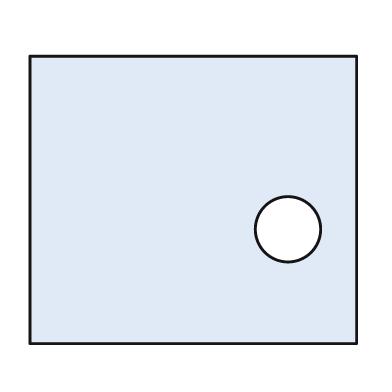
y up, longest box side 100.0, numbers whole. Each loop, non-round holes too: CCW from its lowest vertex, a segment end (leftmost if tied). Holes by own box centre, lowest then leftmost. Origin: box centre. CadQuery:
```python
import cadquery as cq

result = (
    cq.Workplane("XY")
    .moveTo(-50.0, -44.0)
    .lineTo(50.0, -44.0)
    .lineTo(50.0, 44.0)
    .lineTo(-50.0, 44.0)
    .close()
    .moveTo(29.0, -9.0)
    .circle(10.0)
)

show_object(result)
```